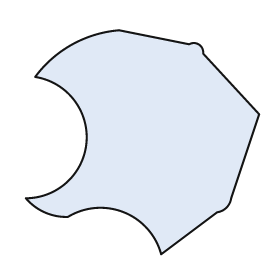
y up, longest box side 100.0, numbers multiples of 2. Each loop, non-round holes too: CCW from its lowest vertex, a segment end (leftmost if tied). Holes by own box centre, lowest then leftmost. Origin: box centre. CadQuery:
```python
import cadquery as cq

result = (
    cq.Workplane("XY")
    .moveTo(8.0, -48.0)
    .lineTo(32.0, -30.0)
    .threePointArc((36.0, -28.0), (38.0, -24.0))
    .lineTo(50.0, 12.0)
    .lineTo(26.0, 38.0)
    .threePointArc((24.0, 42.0), (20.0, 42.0))
    .lineTo(-10.0, 48.0)
    .threePointArc((-30.0, 42.0), (-46.0, 28.0))
    .threePointArc((-24.0, 0.0), (-50.0, -24.0))
    .threePointArc((-42.0, -30.0), (-32.0, -32.0))
    .threePointArc((-8.0, -30.0), (8.0, -48.0))
    .close()
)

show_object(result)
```